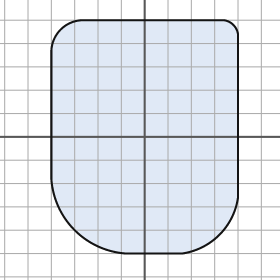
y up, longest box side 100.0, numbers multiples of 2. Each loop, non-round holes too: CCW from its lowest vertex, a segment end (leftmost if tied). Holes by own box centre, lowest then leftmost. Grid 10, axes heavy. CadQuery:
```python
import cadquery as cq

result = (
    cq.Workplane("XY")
    .moveTo(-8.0, -50.0)
    .lineTo(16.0, -50.0)
    .threePointArc((32.0, -42.0), (40.0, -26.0))
    .lineTo(40.0, 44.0)
    .threePointArc((38.0, 48.0), (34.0, 50.0))
    .lineTo(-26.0, 50.0)
    .threePointArc((-36.0, 46.0), (-40.0, 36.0))
    .lineTo(-40.0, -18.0)
    .threePointArc((-30.0, -40.0), (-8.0, -50.0))
    .close()
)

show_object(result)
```